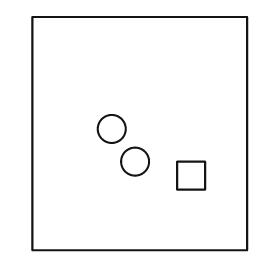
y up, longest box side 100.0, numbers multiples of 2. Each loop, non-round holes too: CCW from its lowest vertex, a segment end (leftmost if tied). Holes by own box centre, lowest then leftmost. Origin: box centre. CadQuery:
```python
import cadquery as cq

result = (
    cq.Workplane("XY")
    .moveTo(-46.0, -50.0)
    .lineTo(46.0, -50.0)
    .lineTo(46.0, 50.0)
    .lineTo(-46.0, 50.0)
    .close()
    .moveTo(16.0, -24.0)
    .lineTo(28.0, -24.0)
    .lineTo(28.0, -12.0)
    .lineTo(16.0, -12.0)
    .close()
    .moveTo(-2.0, -12.0)
    .circle(6.0)
    .moveTo(-12.0, 2.0)
    .circle(6.0)
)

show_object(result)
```